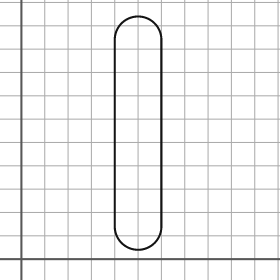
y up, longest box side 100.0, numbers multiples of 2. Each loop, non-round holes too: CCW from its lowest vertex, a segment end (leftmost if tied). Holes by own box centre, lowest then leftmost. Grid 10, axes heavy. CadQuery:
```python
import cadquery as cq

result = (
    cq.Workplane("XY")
    .moveTo(40.0, 14.0)
    .threePointArc((50.0, 4.0), (60.0, 14.0))
    .lineTo(60.0, 94.0)
    .threePointArc((50.0, 104.0), (40.0, 94.0))
    .close()
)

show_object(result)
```